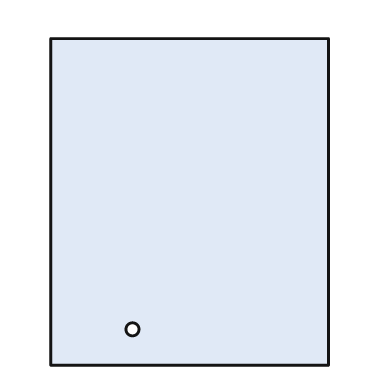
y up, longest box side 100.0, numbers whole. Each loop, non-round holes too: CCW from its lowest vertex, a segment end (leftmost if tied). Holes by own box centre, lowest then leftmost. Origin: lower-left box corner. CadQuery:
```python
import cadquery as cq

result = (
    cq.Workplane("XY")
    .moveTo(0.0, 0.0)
    .lineTo(85.0, 0.0)
    .lineTo(85.0, 100.0)
    .lineTo(0.0, 100.0)
    .close()
    .moveTo(25.0, 11.0)
    .circle(2.0)
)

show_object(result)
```